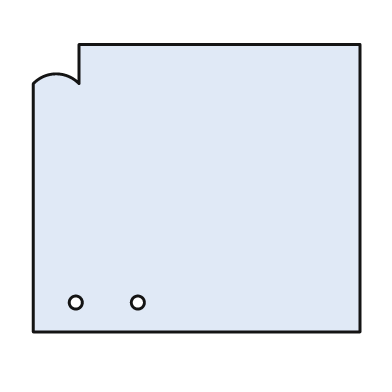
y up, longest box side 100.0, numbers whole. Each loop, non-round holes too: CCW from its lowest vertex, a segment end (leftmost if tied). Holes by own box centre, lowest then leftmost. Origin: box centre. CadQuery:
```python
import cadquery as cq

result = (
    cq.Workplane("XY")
    .moveTo(-50.0, -44.0)
    .lineTo(50.0, -44.0)
    .lineTo(50.0, 44.0)
    .lineTo(-36.0, 44.0)
    .lineTo(-36.0, 32.0)
    .threePointArc((-43.0, 35.0), (-50.0, 32.0))
    .close()
    .moveTo(-37.0, -35.0)
    .circle(2.0)
    .moveTo(-18.0, -35.0)
    .circle(2.0)
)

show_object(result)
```